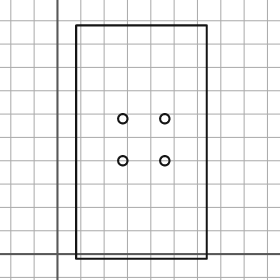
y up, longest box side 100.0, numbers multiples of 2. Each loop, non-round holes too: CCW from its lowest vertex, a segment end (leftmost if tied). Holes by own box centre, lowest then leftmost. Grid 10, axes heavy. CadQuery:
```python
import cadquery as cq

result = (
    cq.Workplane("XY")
    .moveTo(8.0, -2.0)
    .lineTo(64.0, -2.0)
    .lineTo(64.0, 98.0)
    .lineTo(8.0, 98.0)
    .close()
    .moveTo(28.0, 40.0)
    .circle(2.0)
    .moveTo(46.0, 40.0)
    .circle(2.0)
    .moveTo(28.0, 58.0)
    .circle(2.0)
    .moveTo(46.0, 58.0)
    .circle(2.0)
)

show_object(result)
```